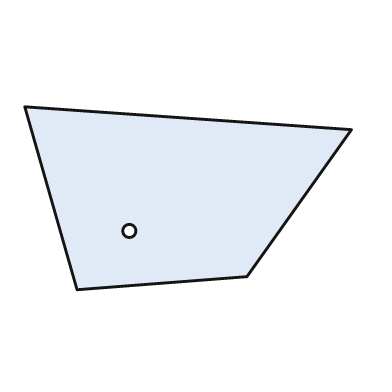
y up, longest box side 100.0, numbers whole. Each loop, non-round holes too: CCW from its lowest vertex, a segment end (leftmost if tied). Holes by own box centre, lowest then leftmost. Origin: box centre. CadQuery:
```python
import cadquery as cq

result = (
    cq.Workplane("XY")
    .moveTo(-34.0, -28.0)
    .lineTo(18.0, -24.0)
    .lineTo(50.0, 21.0)
    .lineTo(-50.0, 28.0)
    .close()
    .moveTo(-18.0, -10.0)
    .circle(2.0)
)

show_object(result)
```